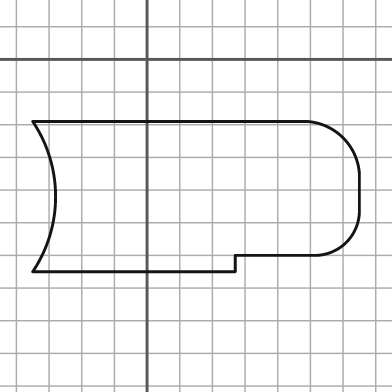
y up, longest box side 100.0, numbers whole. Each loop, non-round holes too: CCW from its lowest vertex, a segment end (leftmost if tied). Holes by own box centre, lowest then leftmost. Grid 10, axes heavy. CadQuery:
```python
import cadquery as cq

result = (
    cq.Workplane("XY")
    .moveTo(-35.0, -65.0)
    .lineTo(27.0, -65.0)
    .lineTo(27.0, -60.0)
    .lineTo(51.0, -60.0)
    .threePointArc((61.0, -56.0), (65.0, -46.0))
    .lineTo(65.0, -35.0)
    .threePointArc((60.0, -24.0), (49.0, -19.0))
    .lineTo(-35.0, -19.0)
    .threePointArc((-28.0, -42.0), (-35.0, -65.0))
    .close()
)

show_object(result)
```